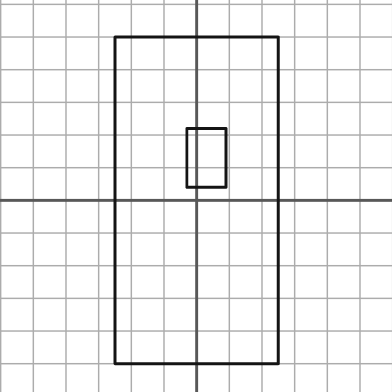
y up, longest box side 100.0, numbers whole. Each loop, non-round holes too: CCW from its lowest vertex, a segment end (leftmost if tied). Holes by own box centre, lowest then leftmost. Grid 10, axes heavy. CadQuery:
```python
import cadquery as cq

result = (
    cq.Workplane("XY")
    .moveTo(-25.0, -50.0)
    .lineTo(25.0, -50.0)
    .lineTo(25.0, 50.0)
    .lineTo(-25.0, 50.0)
    .close()
    .moveTo(-3.0, 4.0)
    .lineTo(9.0, 4.0)
    .lineTo(9.0, 22.0)
    .lineTo(-3.0, 22.0)
    .close()
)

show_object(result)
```